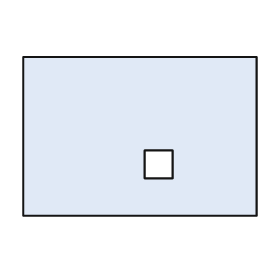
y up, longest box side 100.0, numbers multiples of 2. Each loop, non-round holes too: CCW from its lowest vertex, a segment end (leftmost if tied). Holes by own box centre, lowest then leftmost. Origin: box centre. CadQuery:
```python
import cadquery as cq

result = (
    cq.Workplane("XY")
    .moveTo(-50.0, -34.0)
    .lineTo(50.0, -34.0)
    .lineTo(50.0, 34.0)
    .lineTo(-50.0, 34.0)
    .close()
    .moveTo(2.0, -18.0)
    .lineTo(14.0, -18.0)
    .lineTo(14.0, -6.0)
    .lineTo(2.0, -6.0)
    .close()
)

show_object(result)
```